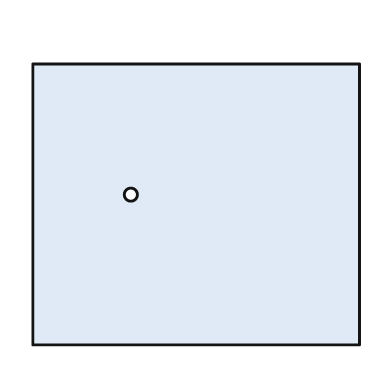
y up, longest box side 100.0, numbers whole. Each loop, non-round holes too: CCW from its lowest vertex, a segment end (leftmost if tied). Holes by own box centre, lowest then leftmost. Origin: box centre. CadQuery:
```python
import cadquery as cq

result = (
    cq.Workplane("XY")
    .moveTo(-50.0, -43.0)
    .lineTo(50.0, -43.0)
    .lineTo(50.0, 43.0)
    .lineTo(-50.0, 43.0)
    .close()
    .moveTo(-20.0, 3.0)
    .circle(2.0)
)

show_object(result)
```